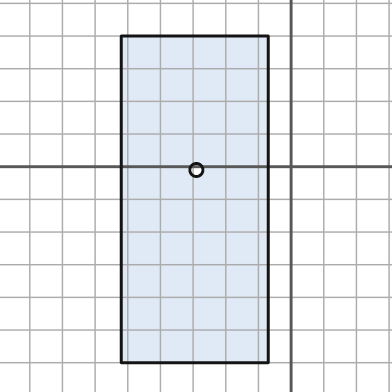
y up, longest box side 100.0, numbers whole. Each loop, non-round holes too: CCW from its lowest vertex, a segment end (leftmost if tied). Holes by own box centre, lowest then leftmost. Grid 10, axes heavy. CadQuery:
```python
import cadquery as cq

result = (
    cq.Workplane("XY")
    .moveTo(-52.0, -60.0)
    .lineTo(-7.0, -60.0)
    .lineTo(-7.0, 40.0)
    .lineTo(-52.0, 40.0)
    .close()
    .moveTo(-29.0, -1.0)
    .circle(2.0)
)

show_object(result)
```